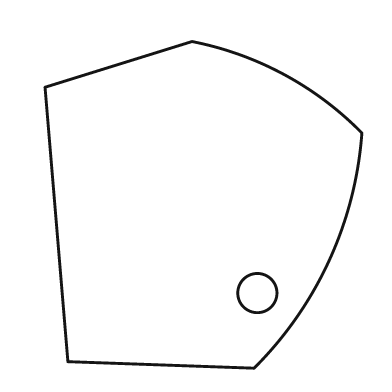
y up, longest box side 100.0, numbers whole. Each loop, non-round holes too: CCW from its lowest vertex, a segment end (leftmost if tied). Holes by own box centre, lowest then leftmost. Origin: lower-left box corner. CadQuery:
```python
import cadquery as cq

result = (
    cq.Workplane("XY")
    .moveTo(64.0, 0.0)
    .threePointArc((87.0, 33.0), (97.0, 72.0))
    .threePointArc((73.0, 90.0), (45.0, 100.0))
    .lineTo(0.0, 86.0)
    .lineTo(7.0, 2.0)
    .close()
    .moveTo(65.0, 23.0)
    .circle(6.0)
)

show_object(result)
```